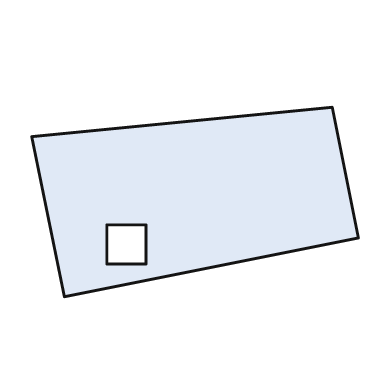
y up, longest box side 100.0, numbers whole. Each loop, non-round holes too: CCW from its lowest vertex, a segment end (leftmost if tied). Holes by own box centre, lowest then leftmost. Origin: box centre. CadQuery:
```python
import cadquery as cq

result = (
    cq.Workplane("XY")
    .moveTo(-40.0, -29.0)
    .lineTo(50.0, -11.0)
    .lineTo(42.0, 29.0)
    .lineTo(-50.0, 20.0)
    .close()
    .moveTo(-27.0, -19.0)
    .lineTo(-15.0, -19.0)
    .lineTo(-15.0, -7.0)
    .lineTo(-27.0, -7.0)
    .close()
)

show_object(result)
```